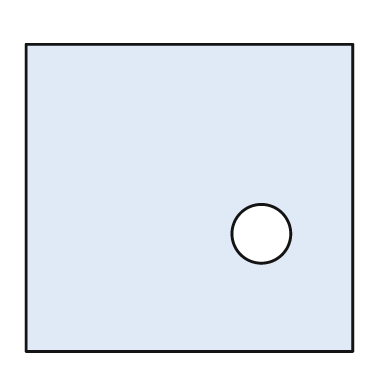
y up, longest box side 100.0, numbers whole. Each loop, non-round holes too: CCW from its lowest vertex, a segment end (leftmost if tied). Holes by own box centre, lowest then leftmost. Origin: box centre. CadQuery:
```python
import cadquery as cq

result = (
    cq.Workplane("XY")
    .moveTo(-50.0, -47.0)
    .lineTo(50.0, -47.0)
    .lineTo(50.0, 47.0)
    .lineTo(-50.0, 47.0)
    .close()
    .moveTo(22.0, -11.0)
    .circle(9.0)
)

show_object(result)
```